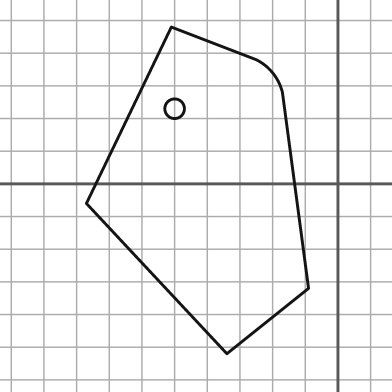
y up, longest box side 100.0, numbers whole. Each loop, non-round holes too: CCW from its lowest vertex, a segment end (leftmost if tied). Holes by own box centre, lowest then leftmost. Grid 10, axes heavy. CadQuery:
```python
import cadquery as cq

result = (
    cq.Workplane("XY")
    .moveTo(-34.0, -52.0)
    .lineTo(-9.0, -32.0)
    .lineTo(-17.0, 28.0)
    .threePointArc((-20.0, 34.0), (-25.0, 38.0))
    .lineTo(-51.0, 48.0)
    .lineTo(-77.0, -6.0)
    .close()
    .moveTo(-50.0, 23.0)
    .circle(3.0)
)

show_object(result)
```